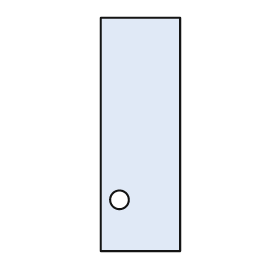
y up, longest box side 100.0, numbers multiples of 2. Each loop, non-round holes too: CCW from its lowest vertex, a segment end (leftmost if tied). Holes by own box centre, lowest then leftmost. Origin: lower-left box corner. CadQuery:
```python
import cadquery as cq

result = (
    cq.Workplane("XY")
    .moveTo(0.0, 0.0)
    .lineTo(34.0, 0.0)
    .lineTo(34.0, 100.0)
    .lineTo(0.0, 100.0)
    .close()
    .moveTo(8.0, 22.0)
    .circle(4.0)
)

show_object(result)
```